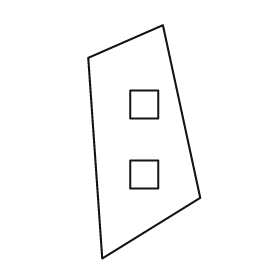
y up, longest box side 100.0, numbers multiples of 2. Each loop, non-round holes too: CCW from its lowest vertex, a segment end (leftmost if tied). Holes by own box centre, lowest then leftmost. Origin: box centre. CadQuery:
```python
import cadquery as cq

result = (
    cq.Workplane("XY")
    .moveTo(-18.0, -50.0)
    .lineTo(24.0, -24.0)
    .lineTo(8.0, 50.0)
    .lineTo(-24.0, 36.0)
    .close()
    .moveTo(-6.0, -20.0)
    .lineTo(6.0, -20.0)
    .lineTo(6.0, -8.0)
    .lineTo(-6.0, -8.0)
    .close()
    .moveTo(-6.0, 10.0)
    .lineTo(6.0, 10.0)
    .lineTo(6.0, 22.0)
    .lineTo(-6.0, 22.0)
    .close()
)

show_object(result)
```